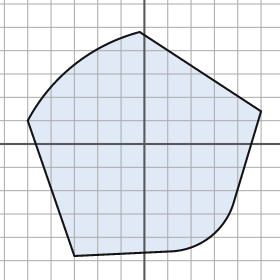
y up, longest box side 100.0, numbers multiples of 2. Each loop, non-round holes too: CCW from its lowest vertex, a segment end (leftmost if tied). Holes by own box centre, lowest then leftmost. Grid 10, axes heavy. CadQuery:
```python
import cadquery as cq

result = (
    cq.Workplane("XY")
    .moveTo(-30.0, -48.0)
    .lineTo(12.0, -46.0)
    .threePointArc((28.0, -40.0), (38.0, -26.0))
    .lineTo(50.0, 14.0)
    .lineTo(-2.0, 48.0)
    .threePointArc((-30.0, 34.0), (-50.0, 10.0))
    .close()
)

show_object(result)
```